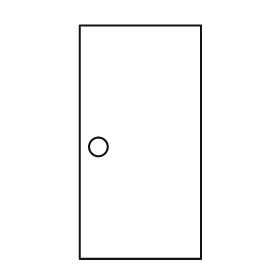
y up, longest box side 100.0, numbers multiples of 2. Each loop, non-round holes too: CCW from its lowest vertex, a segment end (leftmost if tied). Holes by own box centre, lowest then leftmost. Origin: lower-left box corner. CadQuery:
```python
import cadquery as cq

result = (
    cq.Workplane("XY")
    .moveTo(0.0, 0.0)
    .lineTo(52.0, 0.0)
    .lineTo(52.0, 100.0)
    .lineTo(0.0, 100.0)
    .close()
    .moveTo(8.0, 48.0)
    .circle(4.0)
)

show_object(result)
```